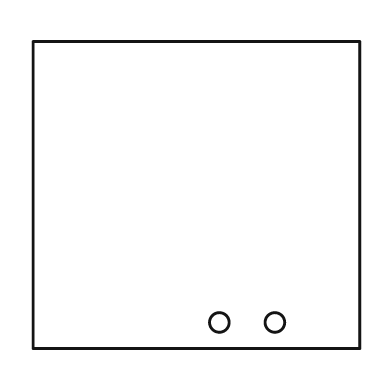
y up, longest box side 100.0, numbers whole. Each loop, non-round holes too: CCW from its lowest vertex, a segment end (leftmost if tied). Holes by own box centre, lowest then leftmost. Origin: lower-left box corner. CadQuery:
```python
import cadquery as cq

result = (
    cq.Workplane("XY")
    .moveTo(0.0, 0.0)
    .lineTo(100.0, 0.0)
    .lineTo(100.0, 94.0)
    .lineTo(0.0, 94.0)
    .close()
    .moveTo(57.0, 8.0)
    .circle(3.0)
    .moveTo(74.0, 8.0)
    .circle(3.0)
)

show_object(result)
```